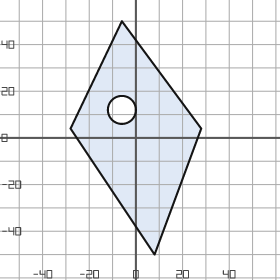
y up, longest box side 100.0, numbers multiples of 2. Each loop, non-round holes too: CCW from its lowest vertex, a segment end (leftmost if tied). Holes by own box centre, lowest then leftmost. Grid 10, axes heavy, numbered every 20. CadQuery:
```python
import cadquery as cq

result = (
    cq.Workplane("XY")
    .moveTo(8.0, -50.0)
    .lineTo(28.0, 4.0)
    .lineTo(-6.0, 50.0)
    .lineTo(-28.0, 4.0)
    .close()
    .moveTo(-6.0, 12.0)
    .circle(6.0)
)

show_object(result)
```